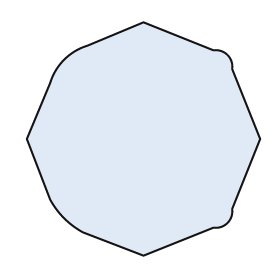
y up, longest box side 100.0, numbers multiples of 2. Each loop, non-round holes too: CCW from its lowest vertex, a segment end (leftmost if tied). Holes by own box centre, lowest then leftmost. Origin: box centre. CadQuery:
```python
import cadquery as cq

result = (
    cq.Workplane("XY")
    .moveTo(0.0, -50.0)
    .lineTo(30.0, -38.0)
    .threePointArc((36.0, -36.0), (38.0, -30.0))
    .lineTo(50.0, 0.0)
    .lineTo(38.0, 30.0)
    .threePointArc((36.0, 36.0), (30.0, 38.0))
    .lineTo(0.0, 50.0)
    .lineTo(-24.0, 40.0)
    .threePointArc((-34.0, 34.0), (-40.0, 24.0))
    .lineTo(-50.0, 0.0)
    .lineTo(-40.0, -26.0)
    .threePointArc((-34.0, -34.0), (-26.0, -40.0))
    .close()
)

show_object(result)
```